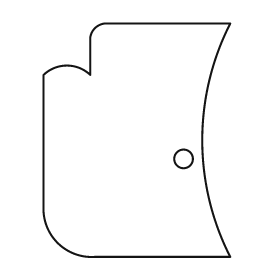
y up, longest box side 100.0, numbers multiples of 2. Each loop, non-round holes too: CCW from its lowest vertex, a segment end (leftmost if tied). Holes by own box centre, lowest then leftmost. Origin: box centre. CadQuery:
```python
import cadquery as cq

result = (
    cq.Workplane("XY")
    .moveTo(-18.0, -50.0)
    .lineTo(40.0, -50.0)
    .threePointArc((28.0, 0.0), (40.0, 50.0))
    .lineTo(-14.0, 50.0)
    .threePointArc((-18.0, 48.0), (-20.0, 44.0))
    .lineTo(-20.0, 28.0)
    .threePointArc((-30.0, 32.0), (-40.0, 28.0))
    .lineTo(-40.0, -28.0)
    .threePointArc((-34.0, -44.0), (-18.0, -50.0))
    .close()
    .moveTo(20.0, -8.0)
    .circle(4.0)
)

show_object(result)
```